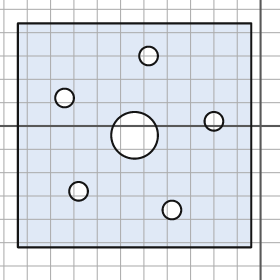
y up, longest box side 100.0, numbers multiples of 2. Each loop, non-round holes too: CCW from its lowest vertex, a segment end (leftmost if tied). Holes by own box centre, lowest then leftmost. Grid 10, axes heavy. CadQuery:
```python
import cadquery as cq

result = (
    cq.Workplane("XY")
    .moveTo(-104.0, -52.0)
    .lineTo(-4.0, -52.0)
    .lineTo(-4.0, 44.0)
    .lineTo(-104.0, 44.0)
    .close()
    .moveTo(-38.0, -36.0)
    .circle(4.0)
    .moveTo(-78.0, -28.0)
    .circle(4.0)
    .moveTo(-54.0, -4.0)
    .circle(10.0)
    .moveTo(-20.0, 2.0)
    .circle(4.0)
    .moveTo(-84.0, 12.0)
    .circle(4.0)
    .moveTo(-48.0, 30.0)
    .circle(4.0)
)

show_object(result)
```